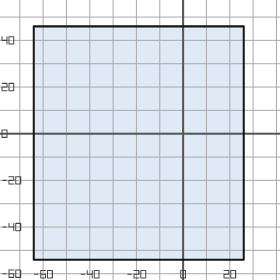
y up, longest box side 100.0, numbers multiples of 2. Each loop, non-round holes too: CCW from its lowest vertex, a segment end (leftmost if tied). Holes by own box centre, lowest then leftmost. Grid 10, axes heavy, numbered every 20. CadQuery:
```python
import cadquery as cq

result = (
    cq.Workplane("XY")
    .moveTo(-64.0, -54.0)
    .lineTo(26.0, -54.0)
    .lineTo(26.0, 46.0)
    .lineTo(-64.0, 46.0)
    .close()
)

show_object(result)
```